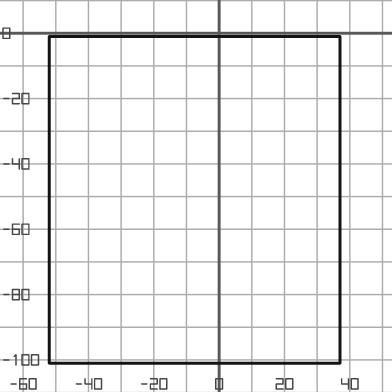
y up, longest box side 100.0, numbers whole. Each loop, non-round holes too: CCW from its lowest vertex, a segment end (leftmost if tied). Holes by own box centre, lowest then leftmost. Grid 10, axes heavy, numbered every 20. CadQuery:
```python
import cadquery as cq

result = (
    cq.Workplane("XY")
    .moveTo(-52.0, -101.0)
    .lineTo(37.0, -101.0)
    .lineTo(37.0, -1.0)
    .lineTo(-52.0, -1.0)
    .close()
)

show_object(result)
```